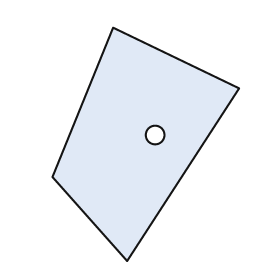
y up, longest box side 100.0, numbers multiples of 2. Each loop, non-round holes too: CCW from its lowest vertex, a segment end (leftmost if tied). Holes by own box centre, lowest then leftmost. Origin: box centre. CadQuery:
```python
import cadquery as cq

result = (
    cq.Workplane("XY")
    .moveTo(-8.0, -50.0)
    .lineTo(40.0, 24.0)
    .lineTo(-14.0, 50.0)
    .lineTo(-40.0, -14.0)
    .close()
    .moveTo(4.0, 4.0)
    .circle(4.0)
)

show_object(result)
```